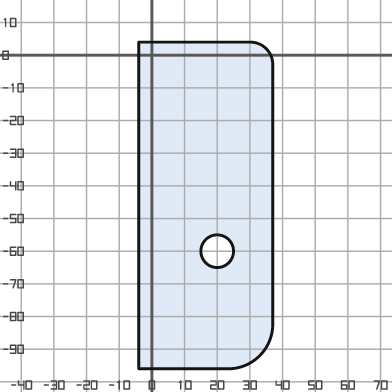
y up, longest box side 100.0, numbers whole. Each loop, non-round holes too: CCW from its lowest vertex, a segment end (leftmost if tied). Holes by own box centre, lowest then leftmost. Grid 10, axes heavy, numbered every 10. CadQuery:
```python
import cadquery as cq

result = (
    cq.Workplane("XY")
    .moveTo(-4.0, -96.0)
    .lineTo(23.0, -96.0)
    .threePointArc((33.0, -92.0), (37.0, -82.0))
    .lineTo(37.0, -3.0)
    .threePointArc((35.0, 2.0), (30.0, 4.0))
    .lineTo(-4.0, 4.0)
    .close()
    .moveTo(20.0, -60.0)
    .circle(5.0)
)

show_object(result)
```